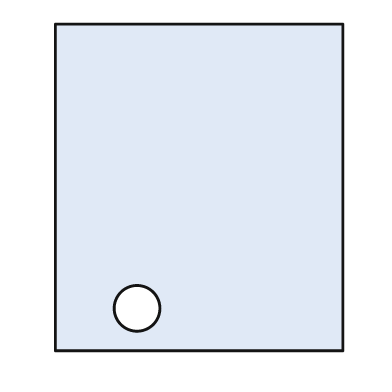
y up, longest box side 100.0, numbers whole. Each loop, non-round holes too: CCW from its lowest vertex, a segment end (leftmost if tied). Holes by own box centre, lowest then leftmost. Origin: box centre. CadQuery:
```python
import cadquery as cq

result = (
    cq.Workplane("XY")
    .moveTo(-44.0, -50.0)
    .lineTo(44.0, -50.0)
    .lineTo(44.0, 50.0)
    .lineTo(-44.0, 50.0)
    .close()
    .moveTo(-19.0, -37.0)
    .circle(7.0)
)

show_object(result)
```